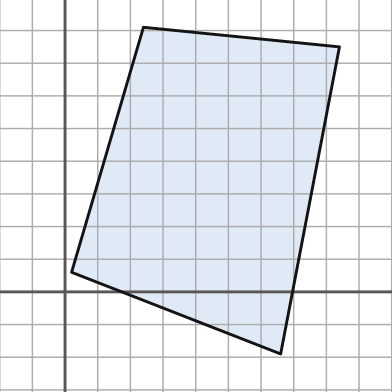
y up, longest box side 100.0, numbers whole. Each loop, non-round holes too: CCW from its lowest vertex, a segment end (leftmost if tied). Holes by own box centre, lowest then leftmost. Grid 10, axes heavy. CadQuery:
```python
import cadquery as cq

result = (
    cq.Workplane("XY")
    .moveTo(66.0, -19.0)
    .lineTo(84.0, 75.0)
    .lineTo(24.0, 81.0)
    .lineTo(2.0, 6.0)
    .close()
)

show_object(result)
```